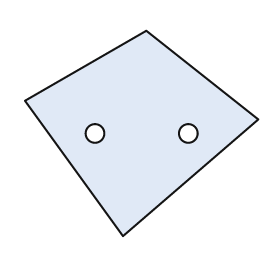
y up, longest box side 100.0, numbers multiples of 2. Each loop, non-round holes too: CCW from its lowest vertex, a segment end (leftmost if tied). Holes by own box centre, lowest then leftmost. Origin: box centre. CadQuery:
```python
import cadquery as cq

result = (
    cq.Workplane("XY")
    .moveTo(-8.0, -44.0)
    .lineTo(50.0, 6.0)
    .lineTo(2.0, 44.0)
    .lineTo(-50.0, 14.0)
    .close()
    .moveTo(-20.0, 0.0)
    .circle(4.0)
    .moveTo(20.0, 0.0)
    .circle(4.0)
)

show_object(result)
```